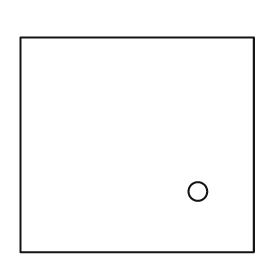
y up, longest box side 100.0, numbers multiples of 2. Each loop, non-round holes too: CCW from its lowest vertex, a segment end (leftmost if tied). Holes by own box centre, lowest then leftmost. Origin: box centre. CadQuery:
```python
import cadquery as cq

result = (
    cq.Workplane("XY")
    .moveTo(-50.0, -46.0)
    .lineTo(50.0, -46.0)
    .lineTo(50.0, 46.0)
    .lineTo(-50.0, 46.0)
    .close()
    .moveTo(26.0, -20.0)
    .circle(4.0)
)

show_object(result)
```